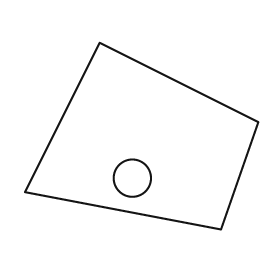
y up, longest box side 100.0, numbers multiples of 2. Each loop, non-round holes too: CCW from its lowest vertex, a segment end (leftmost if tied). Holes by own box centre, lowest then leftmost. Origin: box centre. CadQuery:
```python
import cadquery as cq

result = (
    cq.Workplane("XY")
    .moveTo(34.0, -40.0)
    .lineTo(50.0, 6.0)
    .lineTo(-18.0, 40.0)
    .lineTo(-50.0, -24.0)
    .close()
    .moveTo(-4.0, -18.0)
    .circle(8.0)
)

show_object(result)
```